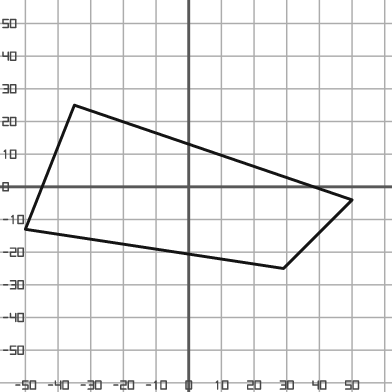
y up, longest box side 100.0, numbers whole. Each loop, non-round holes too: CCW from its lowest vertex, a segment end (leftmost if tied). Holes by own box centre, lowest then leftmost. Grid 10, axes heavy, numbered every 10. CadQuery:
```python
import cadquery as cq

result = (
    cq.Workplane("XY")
    .moveTo(29.0, -25.0)
    .lineTo(50.0, -4.0)
    .lineTo(-35.0, 25.0)
    .lineTo(-50.0, -13.0)
    .close()
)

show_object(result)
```